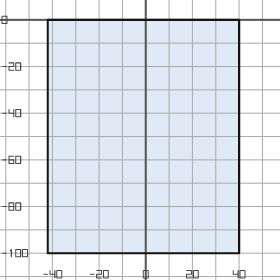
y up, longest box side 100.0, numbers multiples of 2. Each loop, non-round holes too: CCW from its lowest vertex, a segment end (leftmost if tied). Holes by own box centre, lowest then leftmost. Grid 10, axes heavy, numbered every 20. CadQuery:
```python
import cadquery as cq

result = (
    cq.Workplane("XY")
    .moveTo(-42.0, -100.0)
    .lineTo(40.0, -100.0)
    .lineTo(40.0, 0.0)
    .lineTo(-42.0, 0.0)
    .close()
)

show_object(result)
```